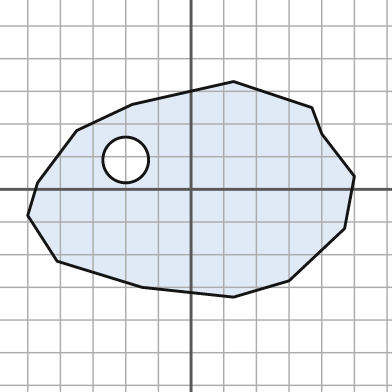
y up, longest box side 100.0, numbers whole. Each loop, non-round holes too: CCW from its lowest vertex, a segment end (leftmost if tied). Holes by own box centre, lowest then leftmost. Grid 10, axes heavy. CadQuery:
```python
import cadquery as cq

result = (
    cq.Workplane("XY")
    .moveTo(13.0, -33.0)
    .lineTo(30.0, -28.0)
    .lineTo(47.0, -12.0)
    .lineTo(50.0, 4.0)
    .lineTo(40.0, 17.0)
    .lineTo(37.0, 25.0)
    .lineTo(13.0, 33.0)
    .lineTo(-18.0, 26.0)
    .lineTo(-35.0, 18.0)
    .lineTo(-47.0, 2.0)
    .lineTo(-50.0, -8.0)
    .lineTo(-41.0, -22.0)
    .lineTo(-15.0, -30.0)
    .close()
    .moveTo(-20.0, 9.0)
    .circle(7.0)
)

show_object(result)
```